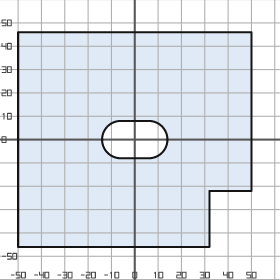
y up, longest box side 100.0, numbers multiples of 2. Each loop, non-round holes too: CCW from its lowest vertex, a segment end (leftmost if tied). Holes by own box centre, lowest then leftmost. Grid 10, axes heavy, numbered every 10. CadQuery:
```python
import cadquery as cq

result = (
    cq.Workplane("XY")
    .moveTo(-50.0, -46.0)
    .lineTo(32.0, -46.0)
    .lineTo(32.0, -22.0)
    .lineTo(50.0, -22.0)
    .lineTo(50.0, 46.0)
    .lineTo(-50.0, 46.0)
    .close()
    .moveTo(-6.0, -8.0)
    .lineTo(6.0, -8.0)
    .threePointArc((14.0, 0.0), (6.0, 8.0))
    .lineTo(-6.0, 8.0)
    .threePointArc((-14.0, 0.0), (-6.0, -8.0))
    .close()
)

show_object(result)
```